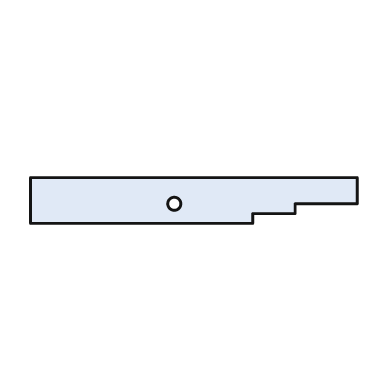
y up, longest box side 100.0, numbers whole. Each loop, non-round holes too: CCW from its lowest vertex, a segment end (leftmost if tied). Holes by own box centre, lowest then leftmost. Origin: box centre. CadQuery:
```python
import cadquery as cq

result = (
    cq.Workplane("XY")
    .moveTo(-50.0, -7.0)
    .lineTo(18.0, -7.0)
    .lineTo(18.0, -4.0)
    .lineTo(31.0, -4.0)
    .lineTo(31.0, -1.0)
    .lineTo(50.0, -1.0)
    .lineTo(50.0, 7.0)
    .lineTo(-50.0, 7.0)
    .close()
    .moveTo(-6.0, -1.0)
    .circle(2.0)
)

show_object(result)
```